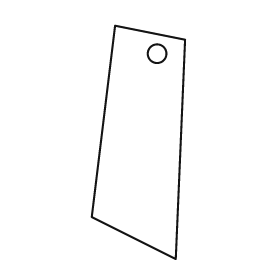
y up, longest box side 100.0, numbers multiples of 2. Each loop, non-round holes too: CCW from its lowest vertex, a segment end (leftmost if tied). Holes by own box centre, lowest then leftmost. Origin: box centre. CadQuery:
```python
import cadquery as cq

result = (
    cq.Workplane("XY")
    .moveTo(16.0, -50.0)
    .lineTo(20.0, 44.0)
    .lineTo(-10.0, 50.0)
    .lineTo(-20.0, -32.0)
    .close()
    .moveTo(8.0, 38.0)
    .circle(4.0)
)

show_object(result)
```